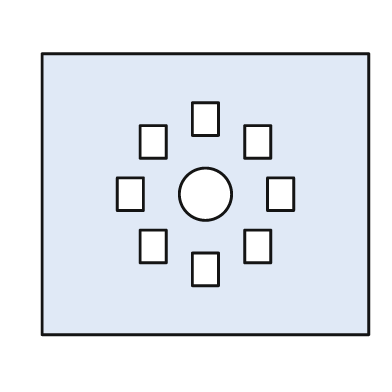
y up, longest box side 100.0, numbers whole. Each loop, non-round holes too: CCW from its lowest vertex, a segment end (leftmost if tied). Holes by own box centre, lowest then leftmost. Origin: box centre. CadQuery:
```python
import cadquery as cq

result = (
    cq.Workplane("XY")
    .moveTo(-50.0, -43.0)
    .lineTo(50.0, -43.0)
    .lineTo(50.0, 43.0)
    .lineTo(-50.0, 43.0)
    .close()
    .moveTo(-4.0, -28.0)
    .lineTo(4.0, -28.0)
    .lineTo(4.0, -18.0)
    .lineTo(-4.0, -18.0)
    .close()
    .moveTo(-20.0, -21.0)
    .lineTo(-12.0, -21.0)
    .lineTo(-12.0, -11.0)
    .lineTo(-20.0, -11.0)
    .close()
    .moveTo(12.0, -21.0)
    .lineTo(20.0, -21.0)
    .lineTo(20.0, -11.0)
    .lineTo(12.0, -11.0)
    .close()
    .moveTo(-27.0, -5.0)
    .lineTo(-19.0, -5.0)
    .lineTo(-19.0, 5.0)
    .lineTo(-27.0, 5.0)
    .close()
    .moveTo(0.0, 0.0)
    .circle(8.0)
    .moveTo(19.0, -5.0)
    .lineTo(27.0, -5.0)
    .lineTo(27.0, 5.0)
    .lineTo(19.0, 5.0)
    .close()
    .moveTo(-20.0, 11.0)
    .lineTo(-12.0, 11.0)
    .lineTo(-12.0, 21.0)
    .lineTo(-20.0, 21.0)
    .close()
    .moveTo(12.0, 11.0)
    .lineTo(20.0, 11.0)
    .lineTo(20.0, 21.0)
    .lineTo(12.0, 21.0)
    .close()
    .moveTo(-4.0, 18.0)
    .lineTo(4.0, 18.0)
    .lineTo(4.0, 28.0)
    .lineTo(-4.0, 28.0)
    .close()
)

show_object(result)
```